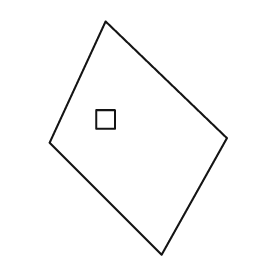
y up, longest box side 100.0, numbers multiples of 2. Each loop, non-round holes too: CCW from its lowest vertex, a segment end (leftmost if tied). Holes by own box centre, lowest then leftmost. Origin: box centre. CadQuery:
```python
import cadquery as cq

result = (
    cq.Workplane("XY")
    .moveTo(10.0, -50.0)
    .lineTo(38.0, 0.0)
    .lineTo(-14.0, 50.0)
    .lineTo(-38.0, -2.0)
    .close()
    .moveTo(-18.0, 4.0)
    .lineTo(-10.0, 4.0)
    .lineTo(-10.0, 12.0)
    .lineTo(-18.0, 12.0)
    .close()
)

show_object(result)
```